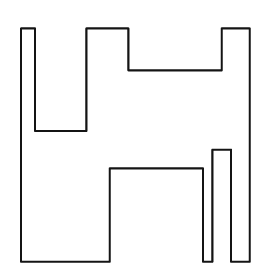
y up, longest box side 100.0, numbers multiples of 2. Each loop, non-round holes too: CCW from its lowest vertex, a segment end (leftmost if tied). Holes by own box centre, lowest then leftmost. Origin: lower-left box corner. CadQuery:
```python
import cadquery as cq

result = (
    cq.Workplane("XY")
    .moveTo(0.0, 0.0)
    .lineTo(38.0, 0.0)
    .lineTo(38.0, 40.0)
    .lineTo(78.0, 40.0)
    .lineTo(78.0, 0.0)
    .lineTo(82.0, 0.0)
    .lineTo(82.0, 48.0)
    .lineTo(90.0, 48.0)
    .lineTo(90.0, 0.0)
    .lineTo(98.0, 0.0)
    .lineTo(98.0, 100.0)
    .lineTo(86.0, 100.0)
    .lineTo(86.0, 82.0)
    .lineTo(46.0, 82.0)
    .lineTo(46.0, 100.0)
    .lineTo(28.0, 100.0)
    .lineTo(28.0, 56.0)
    .lineTo(6.0, 56.0)
    .lineTo(6.0, 100.0)
    .lineTo(0.0, 100.0)
    .close()
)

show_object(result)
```